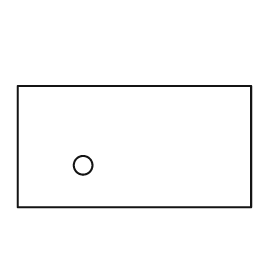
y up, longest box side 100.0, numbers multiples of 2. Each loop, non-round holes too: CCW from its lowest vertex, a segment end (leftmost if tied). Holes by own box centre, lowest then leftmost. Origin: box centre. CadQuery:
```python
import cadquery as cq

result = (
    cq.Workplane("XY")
    .moveTo(-50.0, -26.0)
    .lineTo(50.0, -26.0)
    .lineTo(50.0, 26.0)
    .lineTo(-50.0, 26.0)
    .close()
    .moveTo(-22.0, -8.0)
    .circle(4.0)
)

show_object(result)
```